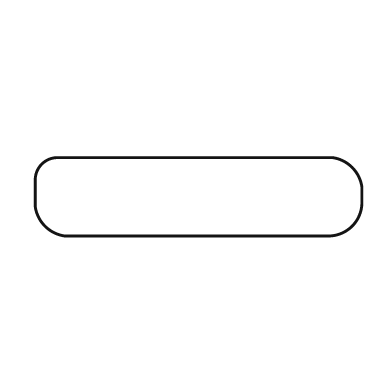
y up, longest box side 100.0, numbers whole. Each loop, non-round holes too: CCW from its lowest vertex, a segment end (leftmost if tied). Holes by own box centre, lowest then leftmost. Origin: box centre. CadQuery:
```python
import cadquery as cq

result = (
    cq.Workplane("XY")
    .moveTo(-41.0, -12.0)
    .lineTo(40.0, -12.0)
    .threePointArc((47.0, -9.0), (50.0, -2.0))
    .lineTo(50.0, 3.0)
    .threePointArc((47.0, 9.0), (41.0, 12.0))
    .lineTo(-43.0, 12.0)
    .threePointArc((-48.0, 10.0), (-50.0, 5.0))
    .lineTo(-50.0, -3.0)
    .threePointArc((-47.0, -9.0), (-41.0, -12.0))
    .close()
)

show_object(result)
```